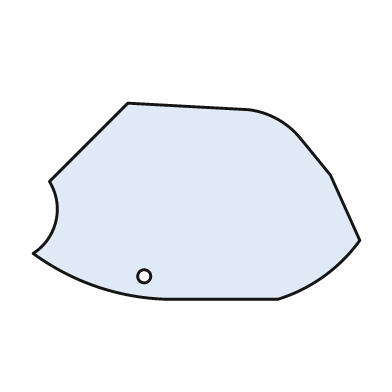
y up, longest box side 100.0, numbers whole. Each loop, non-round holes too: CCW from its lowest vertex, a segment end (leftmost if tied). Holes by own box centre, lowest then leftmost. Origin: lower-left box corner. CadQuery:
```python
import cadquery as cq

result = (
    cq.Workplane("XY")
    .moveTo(40.0, 0.0)
    .lineTo(75.0, 0.0)
    .threePointArc((89.0, 7.0), (100.0, 18.0))
    .lineTo(91.0, 38.0)
    .lineTo(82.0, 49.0)
    .threePointArc((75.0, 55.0), (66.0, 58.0))
    .lineTo(29.0, 60.0)
    .lineTo(5.0, 36.0)
    .threePointArc((7.0, 24.0), (0.0, 14.0))
    .threePointArc((19.0, 4.0), (40.0, 0.0))
    .close()
    .moveTo(34.0, 7.0)
    .circle(2.0)
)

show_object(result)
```